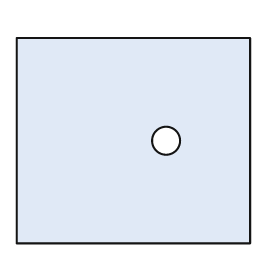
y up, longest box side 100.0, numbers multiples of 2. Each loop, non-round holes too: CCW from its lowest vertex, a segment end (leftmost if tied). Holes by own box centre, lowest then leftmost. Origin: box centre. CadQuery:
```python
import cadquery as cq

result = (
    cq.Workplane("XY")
    .moveTo(-50.0, -44.0)
    .lineTo(50.0, -44.0)
    .lineTo(50.0, 44.0)
    .lineTo(-50.0, 44.0)
    .close()
    .moveTo(14.0, 0.0)
    .circle(6.0)
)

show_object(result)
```